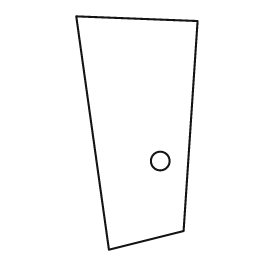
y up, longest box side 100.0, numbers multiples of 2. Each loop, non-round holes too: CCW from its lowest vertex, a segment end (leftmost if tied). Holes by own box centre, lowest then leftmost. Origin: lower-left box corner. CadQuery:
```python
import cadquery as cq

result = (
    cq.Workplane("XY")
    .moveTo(14.0, 0.0)
    .lineTo(46.0, 8.0)
    .lineTo(52.0, 98.0)
    .lineTo(0.0, 100.0)
    .close()
    .moveTo(36.0, 38.0)
    .circle(4.0)
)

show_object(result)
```